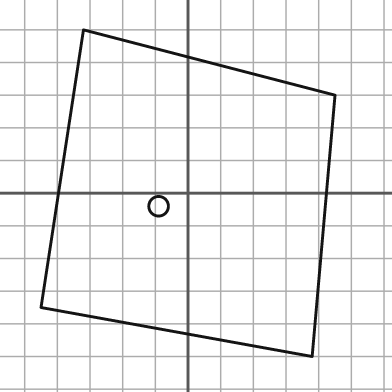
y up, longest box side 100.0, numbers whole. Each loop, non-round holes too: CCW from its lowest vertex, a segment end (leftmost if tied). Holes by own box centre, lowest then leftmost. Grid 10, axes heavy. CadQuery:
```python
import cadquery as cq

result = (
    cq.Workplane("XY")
    .moveTo(38.0, -50.0)
    .lineTo(45.0, 30.0)
    .lineTo(-32.0, 50.0)
    .lineTo(-45.0, -35.0)
    .close()
    .moveTo(-9.0, -4.0)
    .circle(3.0)
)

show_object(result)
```